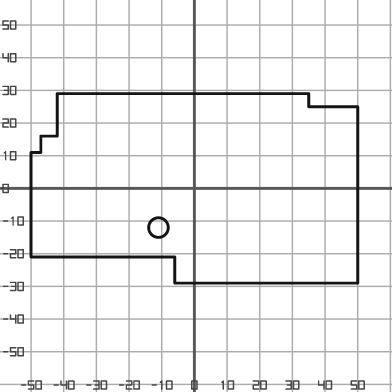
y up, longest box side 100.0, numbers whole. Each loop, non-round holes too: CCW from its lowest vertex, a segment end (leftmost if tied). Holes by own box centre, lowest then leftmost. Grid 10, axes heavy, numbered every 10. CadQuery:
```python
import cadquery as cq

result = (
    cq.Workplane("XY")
    .moveTo(-6.0, -29.0)
    .lineTo(50.0, -29.0)
    .lineTo(50.0, 25.0)
    .lineTo(35.0, 25.0)
    .lineTo(35.0, 29.0)
    .lineTo(-42.0, 29.0)
    .lineTo(-42.0, 16.0)
    .lineTo(-47.0, 16.0)
    .lineTo(-47.0, 11.0)
    .lineTo(-50.0, 11.0)
    .lineTo(-50.0, -21.0)
    .lineTo(-6.0, -21.0)
    .close()
    .moveTo(-11.0, -12.0)
    .circle(3.0)
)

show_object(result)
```